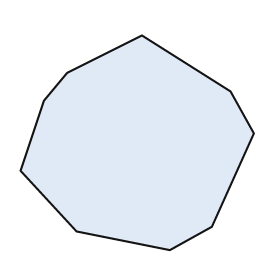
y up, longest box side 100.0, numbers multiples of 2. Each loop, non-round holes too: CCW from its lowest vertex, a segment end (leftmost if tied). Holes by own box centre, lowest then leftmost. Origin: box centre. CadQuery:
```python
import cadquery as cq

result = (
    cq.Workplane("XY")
    .moveTo(14.0, -46.0)
    .lineTo(32.0, -36.0)
    .lineTo(50.0, 4.0)
    .lineTo(40.0, 22.0)
    .lineTo(2.0, 46.0)
    .lineTo(-30.0, 30.0)
    .lineTo(-40.0, 18.0)
    .lineTo(-50.0, -12.0)
    .lineTo(-26.0, -38.0)
    .close()
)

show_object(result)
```